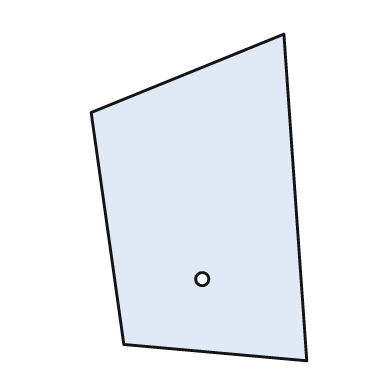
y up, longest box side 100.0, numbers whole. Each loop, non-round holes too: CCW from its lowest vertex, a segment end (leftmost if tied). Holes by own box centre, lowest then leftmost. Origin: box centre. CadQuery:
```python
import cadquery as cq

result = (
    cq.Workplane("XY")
    .moveTo(33.0, -50.0)
    .lineTo(26.0, 50.0)
    .lineTo(-33.0, 26.0)
    .lineTo(-23.0, -45.0)
    .close()
    .moveTo(1.0, -25.0)
    .circle(2.0)
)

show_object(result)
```